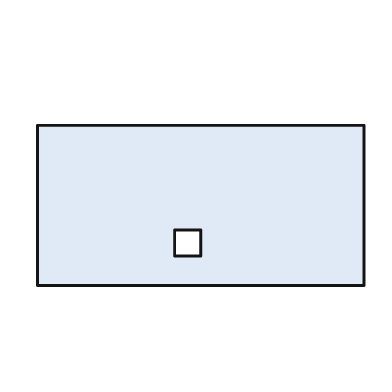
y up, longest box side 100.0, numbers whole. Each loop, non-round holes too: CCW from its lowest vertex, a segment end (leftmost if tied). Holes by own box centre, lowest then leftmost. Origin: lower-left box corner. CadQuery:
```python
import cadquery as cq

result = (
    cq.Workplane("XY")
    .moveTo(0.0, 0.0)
    .lineTo(100.0, 0.0)
    .lineTo(100.0, 49.0)
    .lineTo(0.0, 49.0)
    .close()
    .moveTo(42.0, 9.0)
    .lineTo(50.0, 9.0)
    .lineTo(50.0, 17.0)
    .lineTo(42.0, 17.0)
    .close()
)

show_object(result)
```